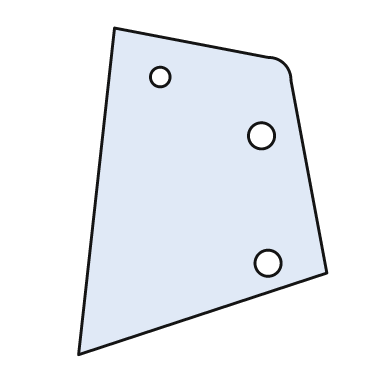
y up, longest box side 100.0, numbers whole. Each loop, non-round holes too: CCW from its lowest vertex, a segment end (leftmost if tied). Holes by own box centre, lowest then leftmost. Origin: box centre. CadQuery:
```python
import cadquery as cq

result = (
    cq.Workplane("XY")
    .moveTo(-38.0, -50.0)
    .lineTo(38.0, -25.0)
    .lineTo(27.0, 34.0)
    .threePointArc((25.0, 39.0), (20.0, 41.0))
    .lineTo(-27.0, 50.0)
    .close()
    .moveTo(20.0, -22.0)
    .circle(4.0)
    .moveTo(18.0, 17.0)
    .circle(4.0)
    .moveTo(-13.0, 35.0)
    .circle(3.0)
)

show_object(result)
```